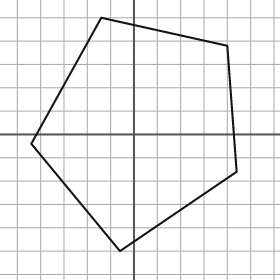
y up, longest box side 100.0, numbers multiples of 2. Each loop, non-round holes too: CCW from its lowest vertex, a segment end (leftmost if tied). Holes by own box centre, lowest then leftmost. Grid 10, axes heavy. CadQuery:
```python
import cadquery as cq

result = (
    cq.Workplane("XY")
    .moveTo(-6.0, -50.0)
    .lineTo(44.0, -16.0)
    .lineTo(40.0, 38.0)
    .lineTo(-14.0, 50.0)
    .lineTo(-44.0, -4.0)
    .close()
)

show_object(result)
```